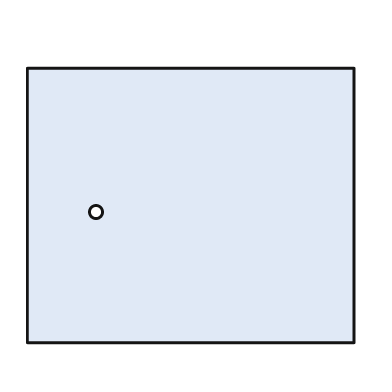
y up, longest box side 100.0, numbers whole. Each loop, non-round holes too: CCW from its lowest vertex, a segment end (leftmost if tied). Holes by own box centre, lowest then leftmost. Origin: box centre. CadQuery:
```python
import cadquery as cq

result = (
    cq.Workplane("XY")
    .moveTo(-50.0, -42.0)
    .lineTo(50.0, -42.0)
    .lineTo(50.0, 42.0)
    .lineTo(-50.0, 42.0)
    .close()
    .moveTo(-29.0, -2.0)
    .circle(2.0)
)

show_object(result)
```